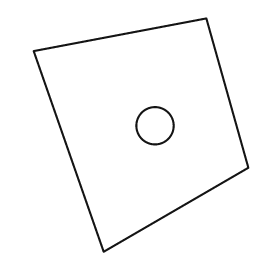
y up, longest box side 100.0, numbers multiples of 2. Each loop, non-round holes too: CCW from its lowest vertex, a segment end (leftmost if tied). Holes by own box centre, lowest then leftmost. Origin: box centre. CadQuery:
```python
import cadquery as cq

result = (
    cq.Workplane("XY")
    .moveTo(-16.0, -50.0)
    .lineTo(46.0, -14.0)
    .lineTo(28.0, 50.0)
    .lineTo(-46.0, 36.0)
    .close()
    .moveTo(6.0, 4.0)
    .circle(8.0)
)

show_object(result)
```